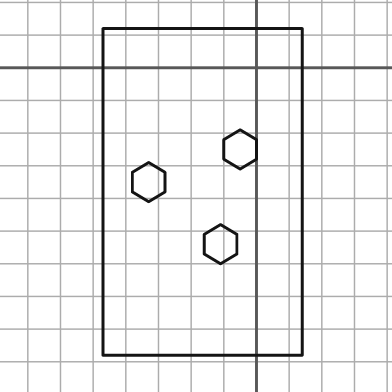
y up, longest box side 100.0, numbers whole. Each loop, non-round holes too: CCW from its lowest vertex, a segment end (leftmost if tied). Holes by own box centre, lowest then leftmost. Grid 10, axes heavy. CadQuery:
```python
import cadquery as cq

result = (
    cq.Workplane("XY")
    .moveTo(-47.0, -88.0)
    .lineTo(14.0, -88.0)
    .lineTo(14.0, 12.0)
    .lineTo(-47.0, 12.0)
    .close()
    .moveTo(-11.0, -60.0)
    .lineTo(-6.0, -57.0)
    .lineTo(-6.0, -51.0)
    .lineTo(-11.0, -48.0)
    .lineTo(-16.0, -51.0)
    .lineTo(-16.0, -57.0)
    .close()
    .moveTo(-33.0, -41.0)
    .lineTo(-28.0, -38.0)
    .lineTo(-28.0, -32.0)
    .lineTo(-33.0, -29.0)
    .lineTo(-38.0, -32.0)
    .lineTo(-38.0, -38.0)
    .close()
    .moveTo(-5.0, -31.0)
    .lineTo(0.0, -28.0)
    .lineTo(0.0, -22.0)
    .lineTo(-5.0, -19.0)
    .lineTo(-10.0, -22.0)
    .lineTo(-10.0, -28.0)
    .close()
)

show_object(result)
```